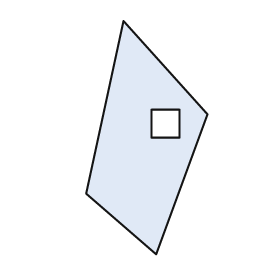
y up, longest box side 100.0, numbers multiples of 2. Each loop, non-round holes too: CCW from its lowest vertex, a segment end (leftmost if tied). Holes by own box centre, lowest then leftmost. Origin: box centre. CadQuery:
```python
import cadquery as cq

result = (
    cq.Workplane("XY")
    .moveTo(4.0, -50.0)
    .lineTo(26.0, 10.0)
    .lineTo(-10.0, 50.0)
    .lineTo(-26.0, -24.0)
    .close()
    .moveTo(2.0, 0.0)
    .lineTo(14.0, 0.0)
    .lineTo(14.0, 12.0)
    .lineTo(2.0, 12.0)
    .close()
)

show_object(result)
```